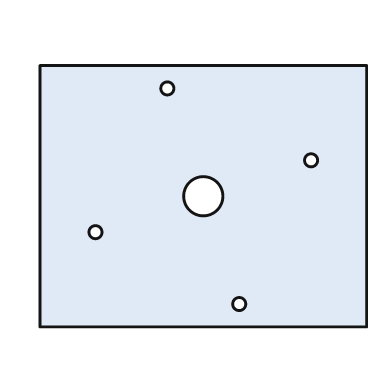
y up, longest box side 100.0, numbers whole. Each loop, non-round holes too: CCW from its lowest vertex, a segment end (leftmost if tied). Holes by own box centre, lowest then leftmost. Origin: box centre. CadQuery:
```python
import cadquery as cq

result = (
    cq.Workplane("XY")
    .moveTo(-50.0, -40.0)
    .lineTo(50.0, -40.0)
    .lineTo(50.0, 40.0)
    .lineTo(-50.0, 40.0)
    .close()
    .moveTo(11.0, -33.0)
    .circle(2.0)
    .moveTo(-33.0, -11.0)
    .circle(2.0)
    .moveTo(0.0, 0.0)
    .circle(6.0)
    .moveTo(33.0, 11.0)
    .circle(2.0)
    .moveTo(-11.0, 33.0)
    .circle(2.0)
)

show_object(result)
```